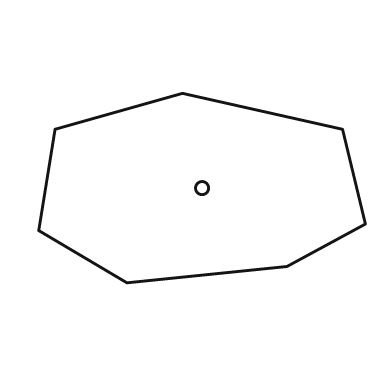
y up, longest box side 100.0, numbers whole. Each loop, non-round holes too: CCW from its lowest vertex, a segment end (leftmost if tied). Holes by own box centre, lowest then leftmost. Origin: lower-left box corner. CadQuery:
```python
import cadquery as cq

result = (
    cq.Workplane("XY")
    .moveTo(27.0, 0.0)
    .lineTo(76.0, 5.0)
    .lineTo(100.0, 18.0)
    .lineTo(93.0, 47.0)
    .lineTo(44.0, 58.0)
    .lineTo(5.0, 47.0)
    .lineTo(0.0, 16.0)
    .close()
    .moveTo(50.0, 29.0)
    .circle(2.0)
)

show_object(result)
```